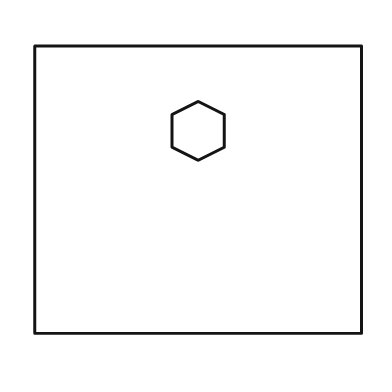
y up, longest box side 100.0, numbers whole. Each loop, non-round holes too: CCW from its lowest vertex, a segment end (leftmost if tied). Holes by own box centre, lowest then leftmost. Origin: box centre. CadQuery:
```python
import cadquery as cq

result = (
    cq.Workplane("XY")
    .moveTo(-50.0, -44.0)
    .lineTo(50.0, -44.0)
    .lineTo(50.0, 44.0)
    .lineTo(-50.0, 44.0)
    .close()
    .moveTo(0.0, 9.0)
    .lineTo(8.0, 13.0)
    .lineTo(8.0, 23.0)
    .lineTo(0.0, 27.0)
    .lineTo(-8.0, 23.0)
    .lineTo(-8.0, 13.0)
    .close()
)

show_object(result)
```